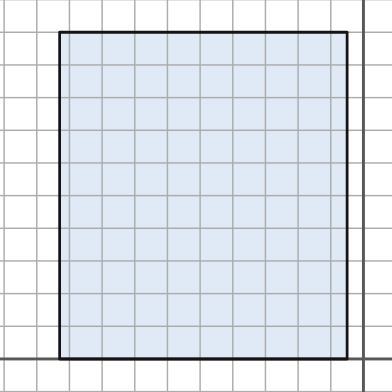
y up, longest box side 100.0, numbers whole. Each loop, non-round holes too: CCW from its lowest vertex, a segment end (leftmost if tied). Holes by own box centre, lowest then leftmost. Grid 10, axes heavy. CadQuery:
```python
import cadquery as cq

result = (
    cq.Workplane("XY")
    .moveTo(-93.0, 0.0)
    .lineTo(-5.0, 0.0)
    .lineTo(-5.0, 100.0)
    .lineTo(-93.0, 100.0)
    .close()
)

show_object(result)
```